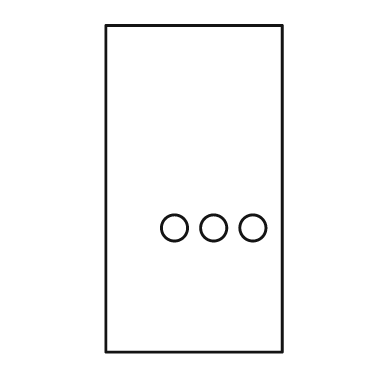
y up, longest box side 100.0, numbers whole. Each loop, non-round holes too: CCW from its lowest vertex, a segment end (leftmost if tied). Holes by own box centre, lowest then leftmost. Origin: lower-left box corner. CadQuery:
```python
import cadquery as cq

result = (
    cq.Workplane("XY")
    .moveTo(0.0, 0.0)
    .lineTo(54.0, 0.0)
    .lineTo(54.0, 100.0)
    .lineTo(0.0, 100.0)
    .close()
    .moveTo(21.0, 38.0)
    .circle(4.0)
    .moveTo(33.0, 38.0)
    .circle(4.0)
    .moveTo(45.0, 38.0)
    .circle(4.0)
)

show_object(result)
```